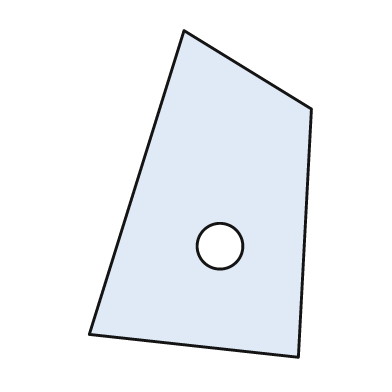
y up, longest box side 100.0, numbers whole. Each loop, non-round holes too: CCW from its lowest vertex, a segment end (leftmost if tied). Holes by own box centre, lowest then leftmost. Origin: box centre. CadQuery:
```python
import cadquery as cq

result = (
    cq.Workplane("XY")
    .moveTo(30.0, -50.0)
    .lineTo(34.0, 26.0)
    .lineTo(-5.0, 50.0)
    .lineTo(-34.0, -43.0)
    .close()
    .moveTo(6.0, -16.0)
    .circle(7.0)
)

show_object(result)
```